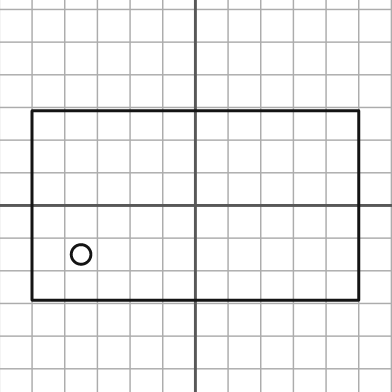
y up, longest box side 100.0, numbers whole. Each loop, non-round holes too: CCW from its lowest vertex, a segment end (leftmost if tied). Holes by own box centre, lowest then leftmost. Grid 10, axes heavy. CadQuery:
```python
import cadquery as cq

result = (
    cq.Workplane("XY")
    .moveTo(-50.0, -29.0)
    .lineTo(50.0, -29.0)
    .lineTo(50.0, 29.0)
    .lineTo(-50.0, 29.0)
    .close()
    .moveTo(-35.0, -15.0)
    .circle(3.0)
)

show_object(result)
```